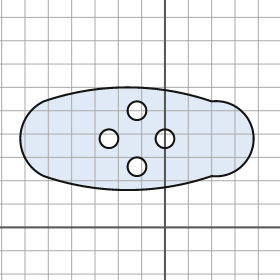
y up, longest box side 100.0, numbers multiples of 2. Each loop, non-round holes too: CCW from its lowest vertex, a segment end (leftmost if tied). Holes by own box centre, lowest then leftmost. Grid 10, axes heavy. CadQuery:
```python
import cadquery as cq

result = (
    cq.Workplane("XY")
    .moveTo(-52.0, 22.0)
    .threePointArc((-16.0, 16.0), (20.0, 22.0))
    .threePointArc((38.0, 38.0), (20.0, 54.0))
    .threePointArc((-16.0, 60.0), (-52.0, 54.0))
    .threePointArc((-62.0, 38.0), (-52.0, 22.0))
    .close()
    .moveTo(-12.0, 26.0)
    .circle(4.0)
    .moveTo(-24.0, 38.0)
    .circle(4.0)
    .moveTo(0.0, 38.0)
    .circle(4.0)
    .moveTo(-12.0, 50.0)
    .circle(4.0)
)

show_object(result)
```